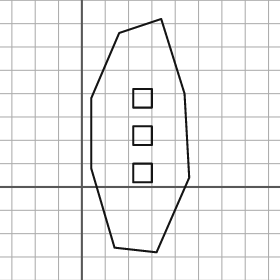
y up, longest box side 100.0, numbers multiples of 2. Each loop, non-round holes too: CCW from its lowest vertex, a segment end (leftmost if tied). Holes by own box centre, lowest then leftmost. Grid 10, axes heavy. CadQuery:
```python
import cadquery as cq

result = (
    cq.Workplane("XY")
    .moveTo(32.0, -28.0)
    .lineTo(46.0, 4.0)
    .lineTo(44.0, 40.0)
    .lineTo(34.0, 72.0)
    .lineTo(16.0, 66.0)
    .lineTo(4.0, 38.0)
    .lineTo(4.0, 8.0)
    .lineTo(14.0, -26.0)
    .close()
    .moveTo(22.0, 2.0)
    .lineTo(30.0, 2.0)
    .lineTo(30.0, 10.0)
    .lineTo(22.0, 10.0)
    .close()
    .moveTo(22.0, 18.0)
    .lineTo(30.0, 18.0)
    .lineTo(30.0, 26.0)
    .lineTo(22.0, 26.0)
    .close()
    .moveTo(22.0, 34.0)
    .lineTo(30.0, 34.0)
    .lineTo(30.0, 42.0)
    .lineTo(22.0, 42.0)
    .close()
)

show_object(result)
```